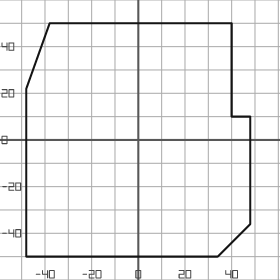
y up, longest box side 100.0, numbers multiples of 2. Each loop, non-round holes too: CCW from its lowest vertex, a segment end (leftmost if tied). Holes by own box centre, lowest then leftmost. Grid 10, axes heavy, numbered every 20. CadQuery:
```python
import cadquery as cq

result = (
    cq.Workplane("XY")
    .moveTo(-48.0, -50.0)
    .lineTo(34.0, -50.0)
    .lineTo(48.0, -36.0)
    .lineTo(48.0, 10.0)
    .lineTo(40.0, 10.0)
    .lineTo(40.0, 50.0)
    .lineTo(-38.0, 50.0)
    .lineTo(-48.0, 22.0)
    .close()
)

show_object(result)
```